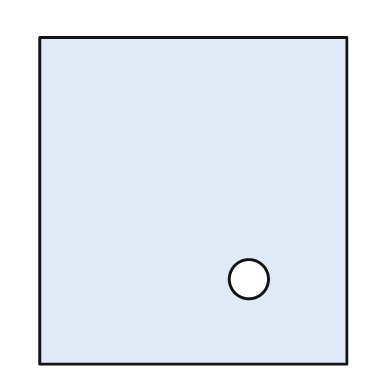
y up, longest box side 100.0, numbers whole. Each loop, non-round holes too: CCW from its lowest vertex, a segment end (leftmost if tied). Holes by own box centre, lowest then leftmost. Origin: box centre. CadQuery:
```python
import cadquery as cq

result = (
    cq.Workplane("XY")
    .moveTo(-47.0, -50.0)
    .lineTo(47.0, -50.0)
    .lineTo(47.0, 50.0)
    .lineTo(-47.0, 50.0)
    .close()
    .moveTo(17.0, -24.0)
    .circle(6.0)
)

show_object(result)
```